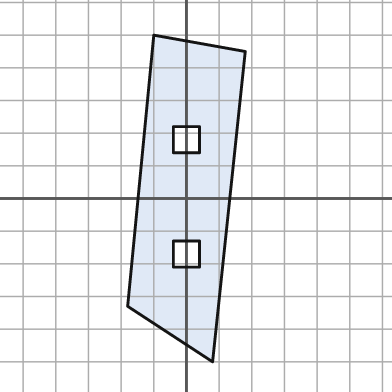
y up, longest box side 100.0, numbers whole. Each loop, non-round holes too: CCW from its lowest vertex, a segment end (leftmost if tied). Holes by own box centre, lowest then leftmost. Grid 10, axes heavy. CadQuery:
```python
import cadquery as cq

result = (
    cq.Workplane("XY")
    .moveTo(8.0, -50.0)
    .lineTo(18.0, 45.0)
    .lineTo(-10.0, 50.0)
    .lineTo(-18.0, -33.0)
    .close()
    .moveTo(-4.0, -21.0)
    .lineTo(4.0, -21.0)
    .lineTo(4.0, -13.0)
    .lineTo(-4.0, -13.0)
    .close()
    .moveTo(-4.0, 14.0)
    .lineTo(4.0, 14.0)
    .lineTo(4.0, 22.0)
    .lineTo(-4.0, 22.0)
    .close()
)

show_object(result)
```